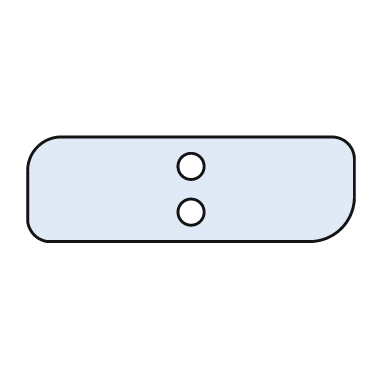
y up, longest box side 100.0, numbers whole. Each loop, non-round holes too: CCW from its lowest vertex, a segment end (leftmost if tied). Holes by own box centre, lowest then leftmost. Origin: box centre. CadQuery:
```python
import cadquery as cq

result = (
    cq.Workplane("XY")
    .moveTo(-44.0, -16.0)
    .lineTo(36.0, -16.0)
    .threePointArc((46.0, -12.0), (50.0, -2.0))
    .lineTo(50.0, 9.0)
    .threePointArc((48.0, 14.0), (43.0, 16.0))
    .lineTo(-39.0, 16.0)
    .threePointArc((-47.0, 13.0), (-50.0, 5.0))
    .lineTo(-50.0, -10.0)
    .threePointArc((-48.0, -14.0), (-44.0, -16.0))
    .close()
    .moveTo(0.0, -7.0)
    .circle(4.0)
    .moveTo(0.0, 7.0)
    .circle(4.0)
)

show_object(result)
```